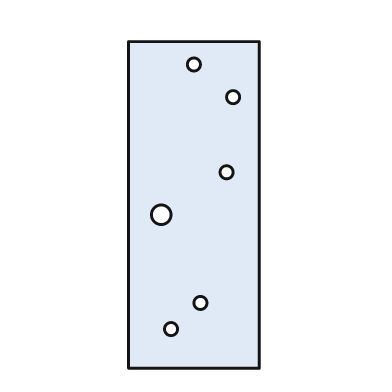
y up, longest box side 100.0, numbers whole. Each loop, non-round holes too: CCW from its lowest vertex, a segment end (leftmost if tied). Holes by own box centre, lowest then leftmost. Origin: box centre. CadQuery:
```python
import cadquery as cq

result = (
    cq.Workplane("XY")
    .moveTo(-20.0, -50.0)
    .lineTo(20.0, -50.0)
    .lineTo(20.0, 50.0)
    .lineTo(-20.0, 50.0)
    .close()
    .moveTo(-7.0, -38.0)
    .circle(2.0)
    .moveTo(2.0, -30.0)
    .circle(2.0)
    .moveTo(-10.0, -3.0)
    .circle(3.0)
    .moveTo(10.0, 10.0)
    .circle(2.0)
    .moveTo(12.0, 33.0)
    .circle(2.0)
    .moveTo(0.0, 43.0)
    .circle(2.0)
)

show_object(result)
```